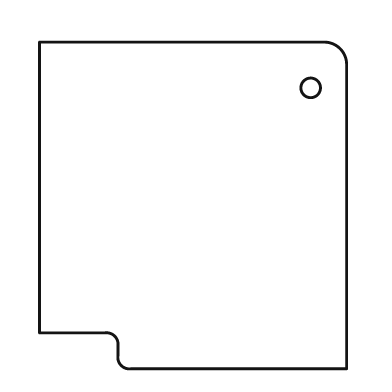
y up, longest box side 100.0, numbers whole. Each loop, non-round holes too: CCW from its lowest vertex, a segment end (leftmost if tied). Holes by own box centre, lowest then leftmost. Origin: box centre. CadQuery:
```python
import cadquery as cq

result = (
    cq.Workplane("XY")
    .moveTo(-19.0, -50.0)
    .lineTo(47.0, -50.0)
    .lineTo(47.0, 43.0)
    .threePointArc((45.0, 48.0), (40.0, 50.0))
    .lineTo(-47.0, 50.0)
    .lineTo(-47.0, -39.0)
    .lineTo(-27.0, -39.0)
    .threePointArc((-24.0, -40.0), (-23.0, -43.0))
    .lineTo(-23.0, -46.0)
    .threePointArc((-22.0, -49.0), (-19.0, -50.0))
    .close()
    .moveTo(36.0, 36.0)
    .circle(3.0)
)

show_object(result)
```